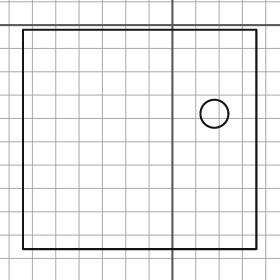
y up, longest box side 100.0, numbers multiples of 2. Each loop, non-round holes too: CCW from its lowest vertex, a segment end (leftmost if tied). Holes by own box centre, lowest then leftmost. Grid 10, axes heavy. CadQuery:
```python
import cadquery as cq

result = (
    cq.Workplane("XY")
    .moveTo(-64.0, -96.0)
    .lineTo(36.0, -96.0)
    .lineTo(36.0, -2.0)
    .lineTo(-64.0, -2.0)
    .close()
    .moveTo(18.0, -38.0)
    .circle(6.0)
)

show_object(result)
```